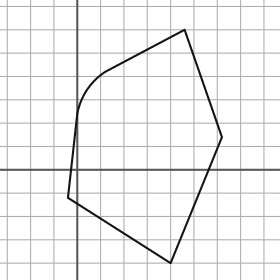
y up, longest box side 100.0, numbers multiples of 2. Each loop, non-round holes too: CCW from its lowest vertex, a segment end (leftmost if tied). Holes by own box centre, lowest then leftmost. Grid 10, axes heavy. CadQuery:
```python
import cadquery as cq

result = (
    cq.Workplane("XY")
    .moveTo(40.0, -40.0)
    .lineTo(62.0, 14.0)
    .lineTo(46.0, 60.0)
    .lineTo(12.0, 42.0)
    .threePointArc((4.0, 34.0), (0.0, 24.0))
    .lineTo(-4.0, -12.0)
    .close()
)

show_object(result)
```